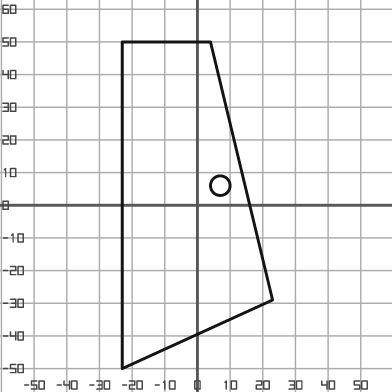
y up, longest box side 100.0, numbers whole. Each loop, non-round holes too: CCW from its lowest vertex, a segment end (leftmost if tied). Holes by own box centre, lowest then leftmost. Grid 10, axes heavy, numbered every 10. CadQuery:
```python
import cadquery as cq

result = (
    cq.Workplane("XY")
    .moveTo(-23.0, -50.0)
    .lineTo(23.0, -29.0)
    .lineTo(4.0, 50.0)
    .lineTo(-23.0, 50.0)
    .close()
    .moveTo(7.0, 6.0)
    .circle(3.0)
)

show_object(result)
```